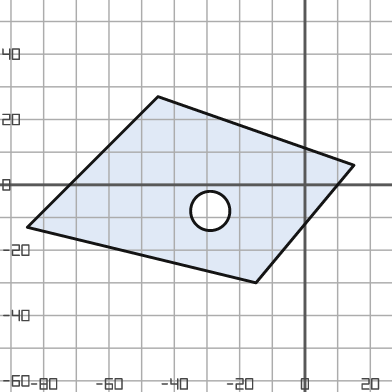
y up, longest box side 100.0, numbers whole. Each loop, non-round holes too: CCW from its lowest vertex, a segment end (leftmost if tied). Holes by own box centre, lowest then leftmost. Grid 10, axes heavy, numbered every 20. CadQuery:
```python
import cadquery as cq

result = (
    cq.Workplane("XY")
    .moveTo(-15.0, -30.0)
    .lineTo(15.0, 6.0)
    .lineTo(-45.0, 27.0)
    .lineTo(-85.0, -13.0)
    .close()
    .moveTo(-29.0, -8.0)
    .circle(6.0)
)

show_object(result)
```